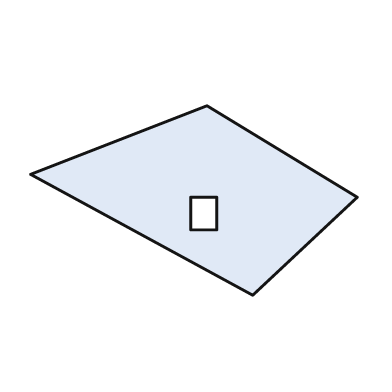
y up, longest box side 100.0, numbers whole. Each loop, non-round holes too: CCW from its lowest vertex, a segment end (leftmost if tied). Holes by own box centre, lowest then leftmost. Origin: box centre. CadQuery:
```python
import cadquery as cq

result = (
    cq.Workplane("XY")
    .moveTo(18.0, -29.0)
    .lineTo(50.0, 1.0)
    .lineTo(4.0, 29.0)
    .lineTo(-50.0, 8.0)
    .close()
    .moveTo(-1.0, -9.0)
    .lineTo(7.0, -9.0)
    .lineTo(7.0, 1.0)
    .lineTo(-1.0, 1.0)
    .close()
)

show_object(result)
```